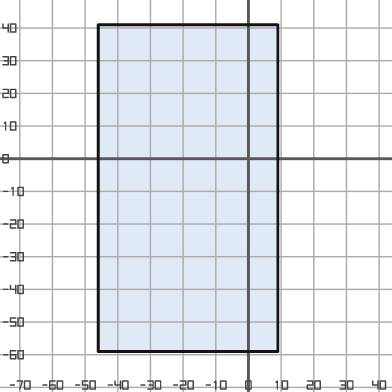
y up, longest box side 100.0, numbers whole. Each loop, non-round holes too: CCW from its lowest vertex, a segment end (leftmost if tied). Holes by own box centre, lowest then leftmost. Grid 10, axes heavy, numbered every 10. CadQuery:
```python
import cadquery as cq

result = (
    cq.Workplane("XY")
    .moveTo(-46.0, -59.0)
    .lineTo(9.0, -59.0)
    .lineTo(9.0, 41.0)
    .lineTo(-46.0, 41.0)
    .close()
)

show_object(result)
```